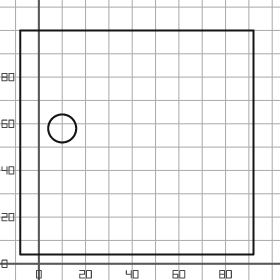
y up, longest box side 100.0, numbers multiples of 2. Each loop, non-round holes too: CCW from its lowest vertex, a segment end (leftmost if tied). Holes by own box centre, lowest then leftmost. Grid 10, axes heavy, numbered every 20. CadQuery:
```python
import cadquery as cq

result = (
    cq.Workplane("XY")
    .moveTo(-8.0, 4.0)
    .lineTo(92.0, 4.0)
    .lineTo(92.0, 100.0)
    .lineTo(-8.0, 100.0)
    .close()
    .moveTo(10.0, 58.0)
    .circle(6.0)
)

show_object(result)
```